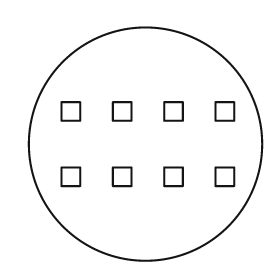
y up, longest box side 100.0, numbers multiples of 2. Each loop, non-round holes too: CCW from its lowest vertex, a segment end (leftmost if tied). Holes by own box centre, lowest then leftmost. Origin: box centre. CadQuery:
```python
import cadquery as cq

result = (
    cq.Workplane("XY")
    .moveTo(0.0, 0.0)
    .circle(50.0)
    .moveTo(-36.0, -18.0)
    .lineTo(-28.0, -18.0)
    .lineTo(-28.0, -10.0)
    .lineTo(-36.0, -10.0)
    .close()
    .moveTo(-14.0, -18.0)
    .lineTo(-6.0, -18.0)
    .lineTo(-6.0, -10.0)
    .lineTo(-14.0, -10.0)
    .close()
    .moveTo(8.0, -18.0)
    .lineTo(16.0, -18.0)
    .lineTo(16.0, -10.0)
    .lineTo(8.0, -10.0)
    .close()
    .moveTo(30.0, -18.0)
    .lineTo(38.0, -18.0)
    .lineTo(38.0, -10.0)
    .lineTo(30.0, -10.0)
    .close()
    .moveTo(-36.0, 10.0)
    .lineTo(-28.0, 10.0)
    .lineTo(-28.0, 18.0)
    .lineTo(-36.0, 18.0)
    .close()
    .moveTo(-14.0, 10.0)
    .lineTo(-6.0, 10.0)
    .lineTo(-6.0, 18.0)
    .lineTo(-14.0, 18.0)
    .close()
    .moveTo(8.0, 10.0)
    .lineTo(16.0, 10.0)
    .lineTo(16.0, 18.0)
    .lineTo(8.0, 18.0)
    .close()
    .moveTo(30.0, 10.0)
    .lineTo(38.0, 10.0)
    .lineTo(38.0, 18.0)
    .lineTo(30.0, 18.0)
    .close()
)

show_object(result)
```